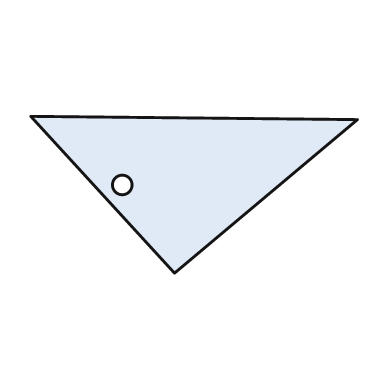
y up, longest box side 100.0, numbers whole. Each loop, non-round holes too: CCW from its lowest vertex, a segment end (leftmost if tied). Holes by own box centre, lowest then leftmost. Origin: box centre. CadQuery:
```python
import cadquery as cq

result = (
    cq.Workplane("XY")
    .moveTo(-6.0, -24.0)
    .lineTo(50.0, 23.0)
    .lineTo(-50.0, 24.0)
    .close()
    .moveTo(-22.0, 3.0)
    .circle(3.0)
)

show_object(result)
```